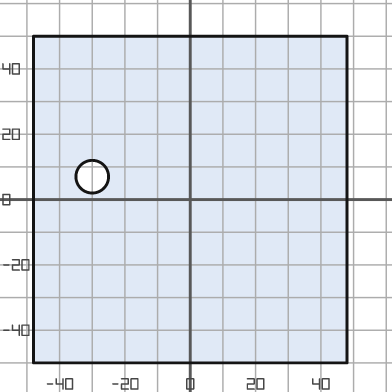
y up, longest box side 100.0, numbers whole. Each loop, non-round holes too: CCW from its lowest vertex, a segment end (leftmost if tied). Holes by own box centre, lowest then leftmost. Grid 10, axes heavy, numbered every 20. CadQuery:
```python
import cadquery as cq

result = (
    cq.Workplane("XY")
    .moveTo(-48.0, -50.0)
    .lineTo(48.0, -50.0)
    .lineTo(48.0, 50.0)
    .lineTo(-48.0, 50.0)
    .close()
    .moveTo(-30.0, 7.0)
    .circle(5.0)
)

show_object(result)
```